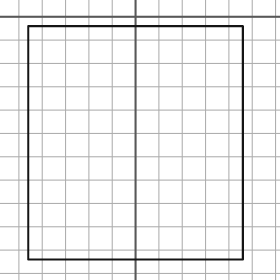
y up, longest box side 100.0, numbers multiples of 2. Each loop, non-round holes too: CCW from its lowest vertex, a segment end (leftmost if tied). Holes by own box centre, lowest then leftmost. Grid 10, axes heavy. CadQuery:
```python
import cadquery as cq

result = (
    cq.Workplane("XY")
    .moveTo(-46.0, -104.0)
    .lineTo(46.0, -104.0)
    .lineTo(46.0, -4.0)
    .lineTo(-46.0, -4.0)
    .close()
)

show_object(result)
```